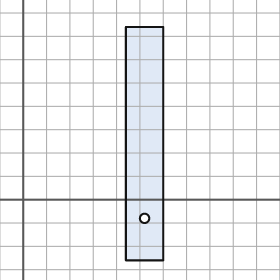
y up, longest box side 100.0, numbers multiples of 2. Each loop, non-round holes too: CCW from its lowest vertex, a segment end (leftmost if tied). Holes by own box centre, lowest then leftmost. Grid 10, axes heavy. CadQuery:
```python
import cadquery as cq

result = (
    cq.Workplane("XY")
    .moveTo(44.0, -26.0)
    .lineTo(60.0, -26.0)
    .lineTo(60.0, 74.0)
    .lineTo(44.0, 74.0)
    .close()
    .moveTo(52.0, -8.0)
    .circle(2.0)
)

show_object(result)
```